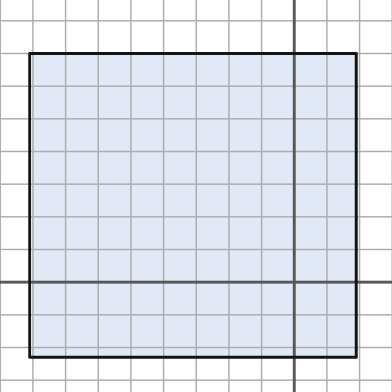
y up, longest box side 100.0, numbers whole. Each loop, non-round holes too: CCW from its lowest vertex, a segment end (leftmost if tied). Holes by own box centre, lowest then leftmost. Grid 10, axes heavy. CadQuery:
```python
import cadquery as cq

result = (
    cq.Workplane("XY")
    .moveTo(-81.0, -23.0)
    .lineTo(19.0, -23.0)
    .lineTo(19.0, 70.0)
    .lineTo(-81.0, 70.0)
    .close()
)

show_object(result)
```